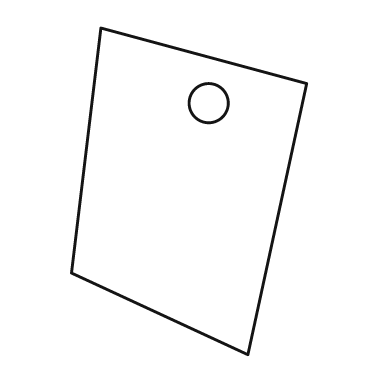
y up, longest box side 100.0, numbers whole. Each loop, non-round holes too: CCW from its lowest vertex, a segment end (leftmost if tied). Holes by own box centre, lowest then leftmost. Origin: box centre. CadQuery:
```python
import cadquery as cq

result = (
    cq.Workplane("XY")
    .moveTo(18.0, -50.0)
    .lineTo(36.0, 33.0)
    .lineTo(-27.0, 50.0)
    .lineTo(-36.0, -25.0)
    .close()
    .moveTo(6.0, 27.0)
    .circle(6.0)
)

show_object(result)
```